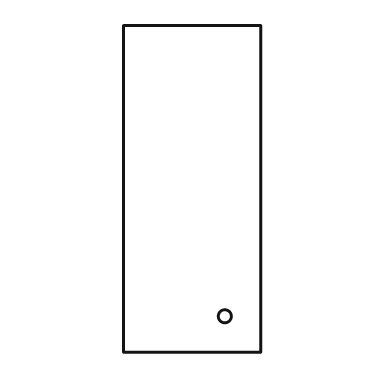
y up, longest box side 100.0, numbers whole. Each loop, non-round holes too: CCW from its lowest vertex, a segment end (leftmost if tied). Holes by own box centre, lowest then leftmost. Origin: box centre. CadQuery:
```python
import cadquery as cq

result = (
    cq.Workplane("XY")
    .moveTo(-21.0, -50.0)
    .lineTo(21.0, -50.0)
    .lineTo(21.0, 50.0)
    .lineTo(-21.0, 50.0)
    .close()
    .moveTo(10.0, -39.0)
    .circle(2.0)
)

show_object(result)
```